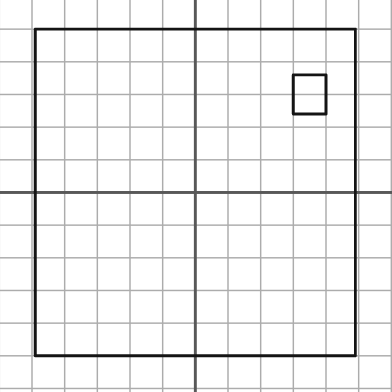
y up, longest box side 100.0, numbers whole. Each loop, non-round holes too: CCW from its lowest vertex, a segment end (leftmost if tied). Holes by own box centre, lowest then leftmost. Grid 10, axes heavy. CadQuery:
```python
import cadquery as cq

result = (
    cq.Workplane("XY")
    .moveTo(-49.0, -50.0)
    .lineTo(49.0, -50.0)
    .lineTo(49.0, 50.0)
    .lineTo(-49.0, 50.0)
    .close()
    .moveTo(30.0, 24.0)
    .lineTo(40.0, 24.0)
    .lineTo(40.0, 36.0)
    .lineTo(30.0, 36.0)
    .close()
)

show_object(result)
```